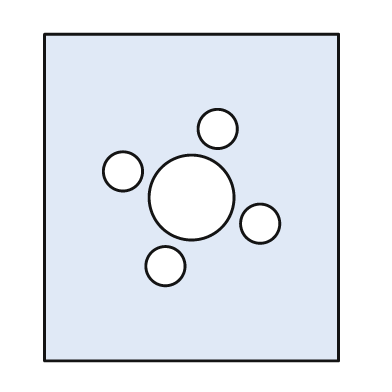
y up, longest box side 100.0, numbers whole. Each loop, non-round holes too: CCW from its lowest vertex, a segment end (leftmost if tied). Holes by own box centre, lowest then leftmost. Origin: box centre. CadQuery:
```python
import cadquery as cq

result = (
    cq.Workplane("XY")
    .moveTo(-45.0, -50.0)
    .lineTo(45.0, -50.0)
    .lineTo(45.0, 50.0)
    .lineTo(-45.0, 50.0)
    .close()
    .moveTo(-8.0, -21.0)
    .circle(6.0)
    .moveTo(21.0, -8.0)
    .circle(6.0)
    .moveTo(0.0, 0.0)
    .circle(13.0)
    .moveTo(-21.0, 8.0)
    .circle(6.0)
    .moveTo(8.0, 21.0)
    .circle(6.0)
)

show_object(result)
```